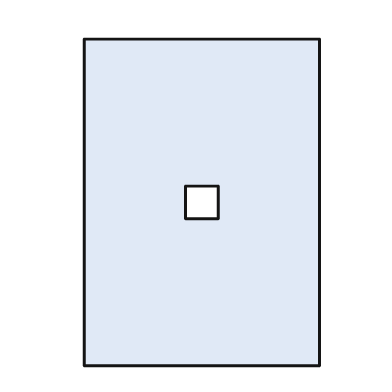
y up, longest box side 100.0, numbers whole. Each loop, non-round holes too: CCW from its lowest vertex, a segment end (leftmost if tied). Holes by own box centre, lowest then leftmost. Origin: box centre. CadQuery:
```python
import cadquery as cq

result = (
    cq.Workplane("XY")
    .moveTo(-36.0, -50.0)
    .lineTo(36.0, -50.0)
    .lineTo(36.0, 50.0)
    .lineTo(-36.0, 50.0)
    .close()
    .moveTo(-5.0, -5.0)
    .lineTo(5.0, -5.0)
    .lineTo(5.0, 5.0)
    .lineTo(-5.0, 5.0)
    .close()
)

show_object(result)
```